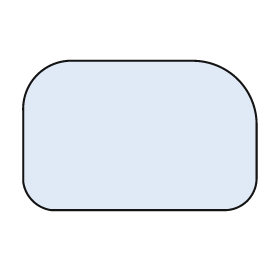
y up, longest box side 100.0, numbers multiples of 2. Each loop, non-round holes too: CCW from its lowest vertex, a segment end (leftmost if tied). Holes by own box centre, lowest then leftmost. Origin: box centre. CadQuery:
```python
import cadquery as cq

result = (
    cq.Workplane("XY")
    .moveTo(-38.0, -32.0)
    .lineTo(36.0, -32.0)
    .threePointArc((46.0, -28.0), (50.0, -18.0))
    .lineTo(50.0, 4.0)
    .threePointArc((42.0, 24.0), (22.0, 32.0))
    .lineTo(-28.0, 32.0)
    .threePointArc((-44.0, 26.0), (-50.0, 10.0))
    .lineTo(-50.0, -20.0)
    .threePointArc((-46.0, -28.0), (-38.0, -32.0))
    .close()
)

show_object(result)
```